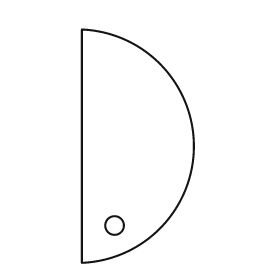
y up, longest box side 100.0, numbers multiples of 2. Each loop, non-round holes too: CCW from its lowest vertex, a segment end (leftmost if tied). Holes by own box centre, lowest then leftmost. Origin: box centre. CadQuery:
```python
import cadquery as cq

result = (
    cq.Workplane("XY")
    .moveTo(-24.0, -50.0)
    .threePointArc((24.0, 0.0), (-24.0, 50.0))
    .close()
    .moveTo(-10.0, -34.0)
    .circle(4.0)
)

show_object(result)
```